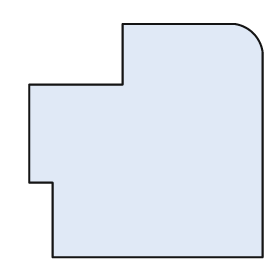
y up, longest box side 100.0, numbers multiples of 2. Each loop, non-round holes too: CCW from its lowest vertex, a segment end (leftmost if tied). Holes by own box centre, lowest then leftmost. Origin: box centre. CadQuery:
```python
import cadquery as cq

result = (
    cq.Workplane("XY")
    .moveTo(-40.0, -50.0)
    .lineTo(50.0, -50.0)
    .lineTo(50.0, 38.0)
    .threePointArc((46.0, 46.0), (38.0, 50.0))
    .lineTo(-10.0, 50.0)
    .lineTo(-10.0, 24.0)
    .lineTo(-50.0, 24.0)
    .lineTo(-50.0, -18.0)
    .lineTo(-40.0, -18.0)
    .close()
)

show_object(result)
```